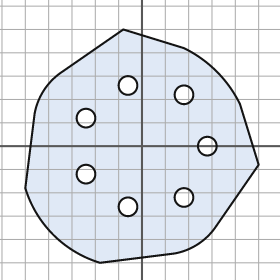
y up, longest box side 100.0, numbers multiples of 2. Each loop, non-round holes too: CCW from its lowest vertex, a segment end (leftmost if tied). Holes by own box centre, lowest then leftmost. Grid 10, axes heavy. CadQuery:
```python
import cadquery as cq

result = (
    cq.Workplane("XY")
    .moveTo(-18.0, -50.0)
    .lineTo(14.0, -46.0)
    .threePointArc((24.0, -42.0), (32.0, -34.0))
    .lineTo(50.0, -8.0)
    .lineTo(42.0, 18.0)
    .threePointArc((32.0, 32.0), (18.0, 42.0))
    .lineTo(-8.0, 50.0)
    .lineTo(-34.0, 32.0)
    .threePointArc((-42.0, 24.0), (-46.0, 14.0))
    .lineTo(-50.0, -18.0)
    .threePointArc((-38.0, -38.0), (-18.0, -50.0))
    .close()
    .moveTo(-6.0, -26.0)
    .circle(4.0)
    .moveTo(18.0, -22.0)
    .circle(4.0)
    .moveTo(-24.0, -12.0)
    .circle(4.0)
    .moveTo(28.0, 0.0)
    .circle(4.0)
    .moveTo(-24.0, 12.0)
    .circle(4.0)
    .moveTo(18.0, 22.0)
    .circle(4.0)
    .moveTo(-6.0, 26.0)
    .circle(4.0)
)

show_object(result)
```